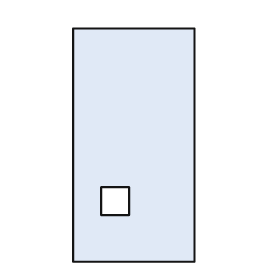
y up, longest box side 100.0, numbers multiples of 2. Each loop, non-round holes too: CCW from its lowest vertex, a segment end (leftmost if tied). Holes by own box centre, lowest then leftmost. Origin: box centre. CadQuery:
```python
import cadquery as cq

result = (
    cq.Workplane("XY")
    .moveTo(-26.0, -50.0)
    .lineTo(26.0, -50.0)
    .lineTo(26.0, 50.0)
    .lineTo(-26.0, 50.0)
    .close()
    .moveTo(-14.0, -30.0)
    .lineTo(-2.0, -30.0)
    .lineTo(-2.0, -18.0)
    .lineTo(-14.0, -18.0)
    .close()
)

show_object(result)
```